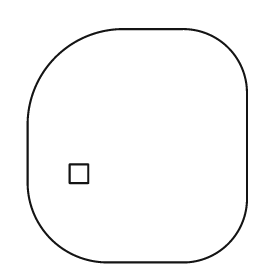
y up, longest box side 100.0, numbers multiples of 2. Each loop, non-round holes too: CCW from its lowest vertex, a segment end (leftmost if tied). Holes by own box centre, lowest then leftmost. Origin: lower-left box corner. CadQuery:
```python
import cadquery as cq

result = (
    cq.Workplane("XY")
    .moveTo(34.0, 0.0)
    .lineTo(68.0, 0.0)
    .threePointArc((86.0, 8.0), (94.0, 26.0))
    .lineTo(94.0, 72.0)
    .threePointArc((86.0, 92.0), (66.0, 100.0))
    .lineTo(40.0, 100.0)
    .threePointArc((12.0, 88.0), (0.0, 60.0))
    .lineTo(0.0, 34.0)
    .threePointArc((10.0, 10.0), (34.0, 0.0))
    .close()
    .moveTo(18.0, 34.0)
    .lineTo(26.0, 34.0)
    .lineTo(26.0, 42.0)
    .lineTo(18.0, 42.0)
    .close()
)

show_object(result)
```